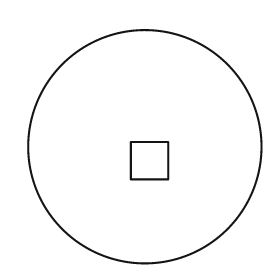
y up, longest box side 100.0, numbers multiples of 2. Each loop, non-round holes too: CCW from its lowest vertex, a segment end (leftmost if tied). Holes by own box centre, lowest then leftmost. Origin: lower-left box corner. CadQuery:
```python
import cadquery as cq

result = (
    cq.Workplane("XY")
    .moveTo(50.0, 50.0)
    .circle(50.0)
    .moveTo(44.0, 36.0)
    .lineTo(60.0, 36.0)
    .lineTo(60.0, 52.0)
    .lineTo(44.0, 52.0)
    .close()
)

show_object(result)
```